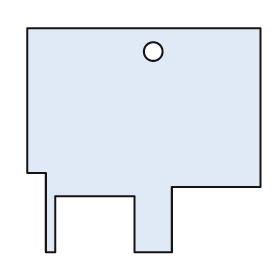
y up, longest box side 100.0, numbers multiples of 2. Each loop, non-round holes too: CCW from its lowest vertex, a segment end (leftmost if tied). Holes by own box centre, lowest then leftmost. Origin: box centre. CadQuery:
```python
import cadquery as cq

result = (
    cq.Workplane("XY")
    .moveTo(-42.0, -48.0)
    .lineTo(-38.0, -48.0)
    .lineTo(-38.0, -24.0)
    .lineTo(-4.0, -24.0)
    .lineTo(-4.0, -48.0)
    .lineTo(12.0, -48.0)
    .lineTo(12.0, -20.0)
    .lineTo(50.0, -20.0)
    .lineTo(50.0, 48.0)
    .lineTo(-50.0, 48.0)
    .lineTo(-50.0, -14.0)
    .lineTo(-42.0, -14.0)
    .close()
    .moveTo(4.0, 38.0)
    .circle(4.0)
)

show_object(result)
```